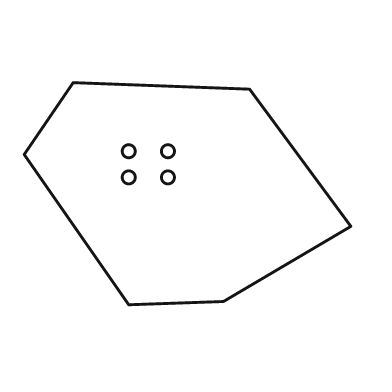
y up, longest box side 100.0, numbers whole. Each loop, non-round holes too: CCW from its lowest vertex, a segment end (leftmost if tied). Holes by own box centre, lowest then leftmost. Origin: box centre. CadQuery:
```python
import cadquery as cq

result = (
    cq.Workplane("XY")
    .moveTo(-18.0, -34.0)
    .lineTo(11.0, -33.0)
    .lineTo(50.0, -10.0)
    .lineTo(19.0, 32.0)
    .lineTo(-35.0, 34.0)
    .lineTo(-50.0, 12.0)
    .close()
    .moveTo(-18.0, 5.0)
    .circle(2.0)
    .moveTo(-6.0, 5.0)
    .circle(2.0)
    .moveTo(-18.0, 13.0)
    .circle(2.0)
    .moveTo(-6.0, 13.0)
    .circle(2.0)
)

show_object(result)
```